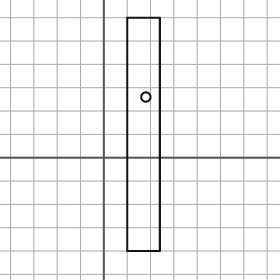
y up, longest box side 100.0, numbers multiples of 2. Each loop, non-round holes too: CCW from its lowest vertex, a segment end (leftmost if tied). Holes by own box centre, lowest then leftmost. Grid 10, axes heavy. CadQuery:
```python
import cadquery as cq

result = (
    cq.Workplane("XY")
    .moveTo(10.0, -40.0)
    .lineTo(24.0, -40.0)
    .lineTo(24.0, 60.0)
    .lineTo(10.0, 60.0)
    .close()
    .moveTo(18.0, 26.0)
    .circle(2.0)
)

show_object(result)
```